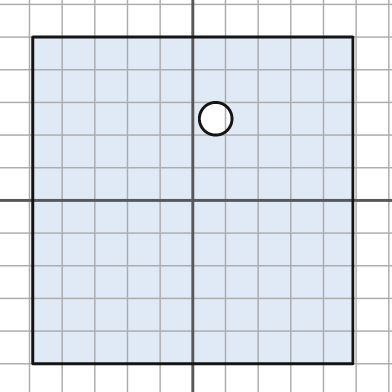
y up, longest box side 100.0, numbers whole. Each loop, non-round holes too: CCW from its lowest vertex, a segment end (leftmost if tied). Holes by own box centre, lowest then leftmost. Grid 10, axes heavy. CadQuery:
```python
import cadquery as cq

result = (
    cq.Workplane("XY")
    .moveTo(-49.0, -50.0)
    .lineTo(49.0, -50.0)
    .lineTo(49.0, 50.0)
    .lineTo(-49.0, 50.0)
    .close()
    .moveTo(7.0, 25.0)
    .circle(5.0)
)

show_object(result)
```